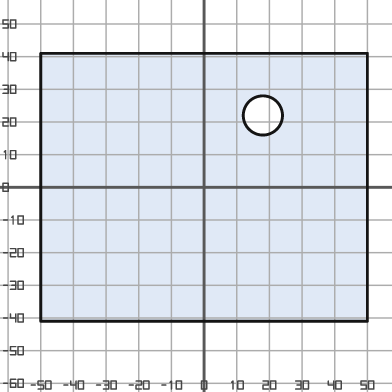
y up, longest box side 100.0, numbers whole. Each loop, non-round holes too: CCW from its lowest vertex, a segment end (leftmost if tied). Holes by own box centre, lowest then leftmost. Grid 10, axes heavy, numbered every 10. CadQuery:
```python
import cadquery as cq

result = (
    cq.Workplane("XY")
    .moveTo(-50.0, -41.0)
    .lineTo(50.0, -41.0)
    .lineTo(50.0, 41.0)
    .lineTo(-50.0, 41.0)
    .close()
    .moveTo(18.0, 22.0)
    .circle(6.0)
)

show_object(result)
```